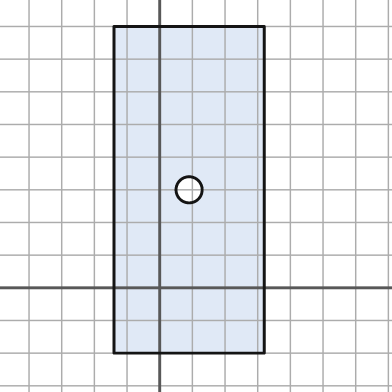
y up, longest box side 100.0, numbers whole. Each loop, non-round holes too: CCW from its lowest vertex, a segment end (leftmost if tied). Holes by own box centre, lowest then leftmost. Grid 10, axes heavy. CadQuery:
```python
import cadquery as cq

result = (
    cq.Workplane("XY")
    .moveTo(-14.0, -20.0)
    .lineTo(32.0, -20.0)
    .lineTo(32.0, 80.0)
    .lineTo(-14.0, 80.0)
    .close()
    .moveTo(9.0, 30.0)
    .circle(4.0)
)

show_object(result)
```